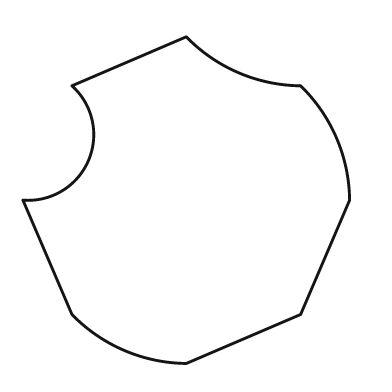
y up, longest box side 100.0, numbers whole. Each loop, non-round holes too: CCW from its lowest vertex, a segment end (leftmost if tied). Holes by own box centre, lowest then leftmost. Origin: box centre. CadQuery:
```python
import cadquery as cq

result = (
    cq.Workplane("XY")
    .moveTo(0.0, -50.0)
    .lineTo(35.0, -35.0)
    .lineTo(50.0, 0.0)
    .threePointArc((46.0, 19.0), (35.0, 35.0))
    .threePointArc((16.0, 39.0), (0.0, 50.0))
    .lineTo(-35.0, 35.0)
    .threePointArc((-30.0, 12.0), (-50.0, 0.0))
    .lineTo(-35.0, -35.0)
    .threePointArc((-19.0, -46.0), (0.0, -50.0))
    .close()
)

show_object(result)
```